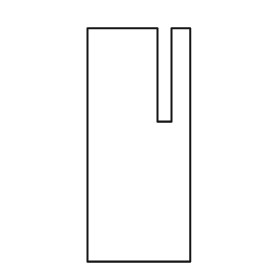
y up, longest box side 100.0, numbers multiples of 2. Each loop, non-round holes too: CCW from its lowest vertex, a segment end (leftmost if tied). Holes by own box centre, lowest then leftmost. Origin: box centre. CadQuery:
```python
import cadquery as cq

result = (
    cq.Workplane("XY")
    .moveTo(-22.0, -50.0)
    .lineTo(22.0, -50.0)
    .lineTo(22.0, 50.0)
    .lineTo(14.0, 50.0)
    .lineTo(14.0, 10.0)
    .lineTo(8.0, 10.0)
    .lineTo(8.0, 50.0)
    .lineTo(-22.0, 50.0)
    .close()
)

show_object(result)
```